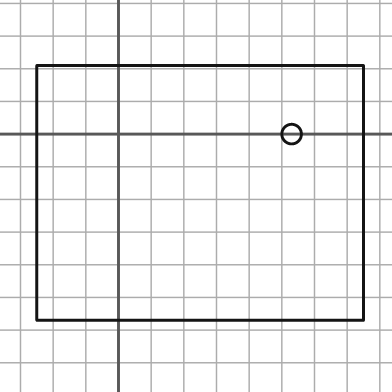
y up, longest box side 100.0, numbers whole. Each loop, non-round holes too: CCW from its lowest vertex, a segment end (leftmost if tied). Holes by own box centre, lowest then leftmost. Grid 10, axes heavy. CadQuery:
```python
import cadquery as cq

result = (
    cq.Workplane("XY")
    .moveTo(-25.0, -57.0)
    .lineTo(75.0, -57.0)
    .lineTo(75.0, 21.0)
    .lineTo(-25.0, 21.0)
    .close()
    .moveTo(53.0, 0.0)
    .circle(3.0)
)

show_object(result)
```